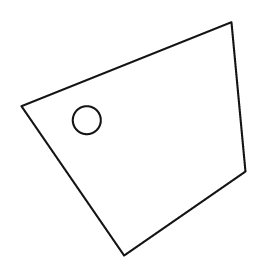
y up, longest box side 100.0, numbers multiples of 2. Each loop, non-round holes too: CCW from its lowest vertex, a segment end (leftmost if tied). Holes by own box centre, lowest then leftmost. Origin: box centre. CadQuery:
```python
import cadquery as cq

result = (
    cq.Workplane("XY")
    .moveTo(-4.0, -50.0)
    .lineTo(48.0, -14.0)
    .lineTo(42.0, 50.0)
    .lineTo(-48.0, 14.0)
    .close()
    .moveTo(-20.0, 8.0)
    .circle(6.0)
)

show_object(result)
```